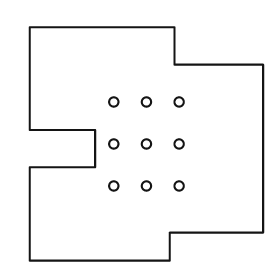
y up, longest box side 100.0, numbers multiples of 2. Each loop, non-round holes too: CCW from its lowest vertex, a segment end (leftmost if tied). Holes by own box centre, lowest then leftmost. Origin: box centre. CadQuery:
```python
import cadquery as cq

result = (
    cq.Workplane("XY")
    .moveTo(-50.0, -50.0)
    .lineTo(10.0, -50.0)
    .lineTo(10.0, -38.0)
    .lineTo(50.0, -38.0)
    .lineTo(50.0, 34.0)
    .lineTo(12.0, 34.0)
    .lineTo(12.0, 50.0)
    .lineTo(-50.0, 50.0)
    .lineTo(-50.0, 6.0)
    .lineTo(-22.0, 6.0)
    .lineTo(-22.0, -10.0)
    .lineTo(-50.0, -10.0)
    .close()
    .moveTo(-14.0, -18.0)
    .circle(2.0)
    .moveTo(0.0, -18.0)
    .circle(2.0)
    .moveTo(14.0, -18.0)
    .circle(2.0)
    .moveTo(-14.0, 0.0)
    .circle(2.0)
    .moveTo(0.0, 0.0)
    .circle(2.0)
    .moveTo(14.0, 0.0)
    .circle(2.0)
    .moveTo(-14.0, 18.0)
    .circle(2.0)
    .moveTo(0.0, 18.0)
    .circle(2.0)
    .moveTo(14.0, 18.0)
    .circle(2.0)
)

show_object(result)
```